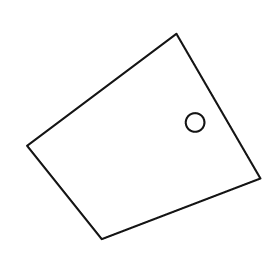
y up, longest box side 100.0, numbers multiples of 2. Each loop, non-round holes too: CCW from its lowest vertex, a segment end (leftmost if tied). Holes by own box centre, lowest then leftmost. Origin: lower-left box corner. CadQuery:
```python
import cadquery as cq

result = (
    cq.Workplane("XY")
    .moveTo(32.0, 0.0)
    .lineTo(100.0, 26.0)
    .lineTo(64.0, 88.0)
    .lineTo(0.0, 40.0)
    .close()
    .moveTo(72.0, 50.0)
    .circle(4.0)
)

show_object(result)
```